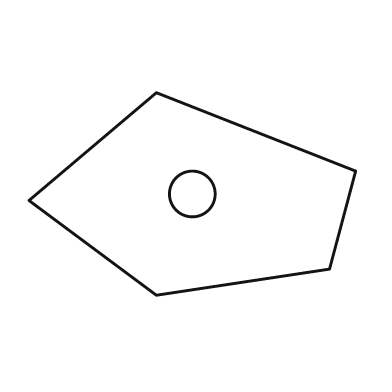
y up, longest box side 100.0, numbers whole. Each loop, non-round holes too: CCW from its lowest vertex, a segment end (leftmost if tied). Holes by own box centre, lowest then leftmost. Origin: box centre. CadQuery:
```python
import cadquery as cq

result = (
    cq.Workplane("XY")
    .moveTo(-11.0, -31.0)
    .lineTo(42.0, -23.0)
    .lineTo(50.0, 7.0)
    .lineTo(-11.0, 31.0)
    .lineTo(-50.0, -2.0)
    .close()
    .moveTo(0.0, 0.0)
    .circle(7.0)
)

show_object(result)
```